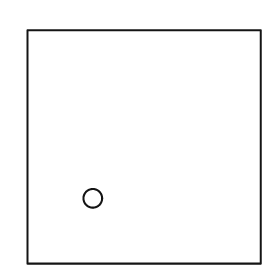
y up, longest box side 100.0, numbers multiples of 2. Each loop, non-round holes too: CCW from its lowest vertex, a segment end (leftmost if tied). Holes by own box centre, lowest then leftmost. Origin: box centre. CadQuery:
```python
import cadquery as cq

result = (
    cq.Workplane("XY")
    .moveTo(-50.0, -50.0)
    .lineTo(50.0, -50.0)
    .lineTo(50.0, 50.0)
    .lineTo(-50.0, 50.0)
    .close()
    .moveTo(-22.0, -22.0)
    .circle(4.0)
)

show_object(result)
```